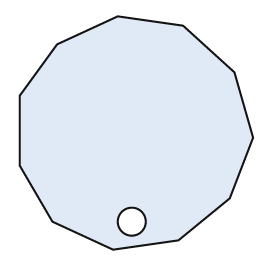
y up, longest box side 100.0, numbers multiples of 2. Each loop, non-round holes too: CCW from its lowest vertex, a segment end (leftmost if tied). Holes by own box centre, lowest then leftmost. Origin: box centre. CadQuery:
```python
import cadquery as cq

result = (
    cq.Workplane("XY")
    .moveTo(-10.0, -50.0)
    .lineTo(18.0, -46.0)
    .lineTo(40.0, -28.0)
    .lineTo(50.0, -2.0)
    .lineTo(42.0, 26.0)
    .lineTo(20.0, 46.0)
    .lineTo(-8.0, 50.0)
    .lineTo(-34.0, 38.0)
    .lineTo(-50.0, 16.0)
    .lineTo(-50.0, -14.0)
    .lineTo(-36.0, -38.0)
    .close()
    .moveTo(-2.0, -38.0)
    .circle(6.0)
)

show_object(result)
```